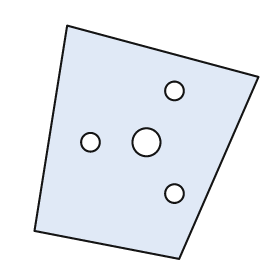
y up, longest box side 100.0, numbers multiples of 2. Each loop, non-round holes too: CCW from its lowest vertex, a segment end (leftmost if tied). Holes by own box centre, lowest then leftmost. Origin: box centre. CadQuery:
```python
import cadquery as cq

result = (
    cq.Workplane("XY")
    .moveTo(14.0, -50.0)
    .lineTo(48.0, 28.0)
    .lineTo(-34.0, 50.0)
    .lineTo(-48.0, -38.0)
    .close()
    .moveTo(12.0, -22.0)
    .circle(4.0)
    .moveTo(-24.0, 0.0)
    .circle(4.0)
    .moveTo(0.0, 0.0)
    .circle(6.0)
    .moveTo(12.0, 22.0)
    .circle(4.0)
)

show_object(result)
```